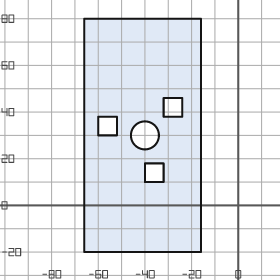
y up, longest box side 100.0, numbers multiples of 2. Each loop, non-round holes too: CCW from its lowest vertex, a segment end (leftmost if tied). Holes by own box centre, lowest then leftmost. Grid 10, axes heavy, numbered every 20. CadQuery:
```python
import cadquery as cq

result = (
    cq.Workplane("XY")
    .moveTo(-66.0, -20.0)
    .lineTo(-16.0, -20.0)
    .lineTo(-16.0, 80.0)
    .lineTo(-66.0, 80.0)
    .close()
    .moveTo(-40.0, 10.0)
    .lineTo(-32.0, 10.0)
    .lineTo(-32.0, 18.0)
    .lineTo(-40.0, 18.0)
    .close()
    .moveTo(-40.0, 30.0)
    .circle(6.0)
    .moveTo(-60.0, 30.0)
    .lineTo(-52.0, 30.0)
    .lineTo(-52.0, 38.0)
    .lineTo(-60.0, 38.0)
    .close()
    .moveTo(-32.0, 38.0)
    .lineTo(-24.0, 38.0)
    .lineTo(-24.0, 46.0)
    .lineTo(-32.0, 46.0)
    .close()
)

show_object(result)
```